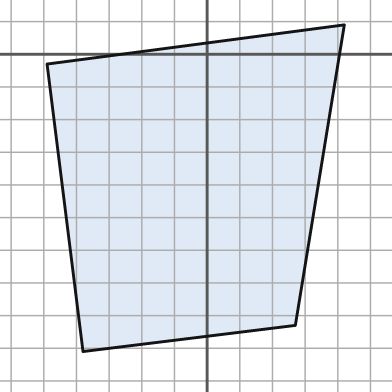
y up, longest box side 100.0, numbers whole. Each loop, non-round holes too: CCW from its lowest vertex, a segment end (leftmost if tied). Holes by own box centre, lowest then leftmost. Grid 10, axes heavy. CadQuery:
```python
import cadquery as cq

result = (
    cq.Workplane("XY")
    .moveTo(-38.0, -91.0)
    .lineTo(27.0, -83.0)
    .lineTo(42.0, 9.0)
    .lineTo(-49.0, -3.0)
    .close()
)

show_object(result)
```